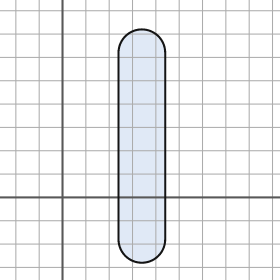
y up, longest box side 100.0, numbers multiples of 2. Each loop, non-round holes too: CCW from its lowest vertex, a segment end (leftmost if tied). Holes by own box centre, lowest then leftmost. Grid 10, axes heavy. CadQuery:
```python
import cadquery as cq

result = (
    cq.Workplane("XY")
    .moveTo(24.0, -18.0)
    .threePointArc((34.0, -28.0), (44.0, -18.0))
    .lineTo(44.0, 62.0)
    .threePointArc((34.0, 72.0), (24.0, 62.0))
    .close()
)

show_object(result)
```